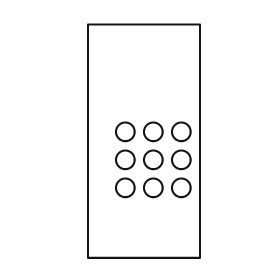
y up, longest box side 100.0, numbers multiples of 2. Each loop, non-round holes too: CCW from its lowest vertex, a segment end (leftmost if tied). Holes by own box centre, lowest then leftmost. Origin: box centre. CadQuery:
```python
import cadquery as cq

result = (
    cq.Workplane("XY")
    .moveTo(-24.0, -50.0)
    .lineTo(24.0, -50.0)
    .lineTo(24.0, 50.0)
    .lineTo(-24.0, 50.0)
    .close()
    .moveTo(-8.0, -20.0)
    .circle(4.0)
    .moveTo(4.0, -20.0)
    .circle(4.0)
    .moveTo(16.0, -20.0)
    .circle(4.0)
    .moveTo(-8.0, -8.0)
    .circle(4.0)
    .moveTo(4.0, -8.0)
    .circle(4.0)
    .moveTo(16.0, -8.0)
    .circle(4.0)
    .moveTo(-8.0, 4.0)
    .circle(4.0)
    .moveTo(4.0, 4.0)
    .circle(4.0)
    .moveTo(16.0, 4.0)
    .circle(4.0)
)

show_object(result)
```